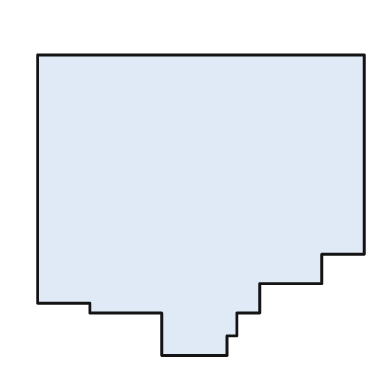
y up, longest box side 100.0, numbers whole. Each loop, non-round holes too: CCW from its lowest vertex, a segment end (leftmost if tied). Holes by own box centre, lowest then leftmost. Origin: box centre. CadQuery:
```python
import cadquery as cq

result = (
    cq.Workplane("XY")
    .moveTo(-12.0, -46.0)
    .lineTo(8.0, -46.0)
    .lineTo(8.0, -40.0)
    .lineTo(11.0, -40.0)
    .lineTo(11.0, -33.0)
    .lineTo(18.0, -33.0)
    .lineTo(18.0, -24.0)
    .lineTo(37.0, -24.0)
    .lineTo(37.0, -15.0)
    .lineTo(50.0, -15.0)
    .lineTo(50.0, 46.0)
    .lineTo(-50.0, 46.0)
    .lineTo(-50.0, -30.0)
    .lineTo(-34.0, -30.0)
    .lineTo(-34.0, -33.0)
    .lineTo(-12.0, -33.0)
    .close()
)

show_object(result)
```